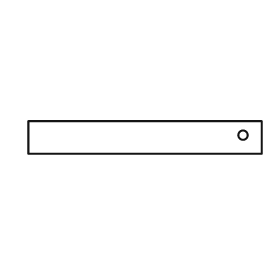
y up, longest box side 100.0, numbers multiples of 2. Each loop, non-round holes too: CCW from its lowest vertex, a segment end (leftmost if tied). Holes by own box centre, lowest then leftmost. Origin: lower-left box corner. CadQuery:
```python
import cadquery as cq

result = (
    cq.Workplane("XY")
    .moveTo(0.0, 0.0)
    .lineTo(100.0, 0.0)
    .lineTo(100.0, 14.0)
    .lineTo(0.0, 14.0)
    .close()
    .moveTo(92.0, 8.0)
    .circle(2.0)
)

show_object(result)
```